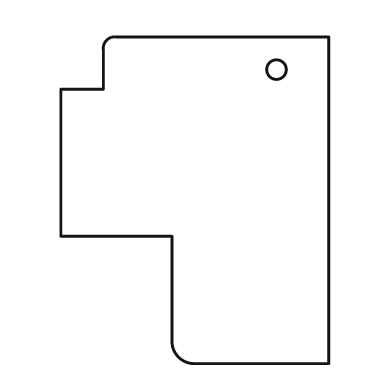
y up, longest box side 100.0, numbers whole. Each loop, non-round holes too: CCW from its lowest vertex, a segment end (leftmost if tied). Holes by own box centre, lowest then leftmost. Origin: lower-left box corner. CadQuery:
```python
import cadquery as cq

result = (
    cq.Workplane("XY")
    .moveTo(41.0, 0.0)
    .lineTo(82.0, 0.0)
    .lineTo(82.0, 100.0)
    .lineTo(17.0, 100.0)
    .threePointArc((14.0, 99.0), (13.0, 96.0))
    .lineTo(13.0, 84.0)
    .lineTo(0.0, 84.0)
    .lineTo(0.0, 39.0)
    .lineTo(34.0, 39.0)
    .lineTo(34.0, 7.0)
    .threePointArc((36.0, 2.0), (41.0, 0.0))
    .close()
    .moveTo(66.0, 90.0)
    .circle(3.0)
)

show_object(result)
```